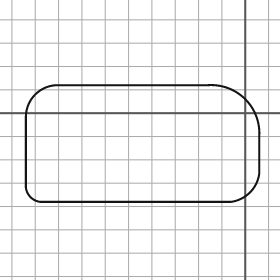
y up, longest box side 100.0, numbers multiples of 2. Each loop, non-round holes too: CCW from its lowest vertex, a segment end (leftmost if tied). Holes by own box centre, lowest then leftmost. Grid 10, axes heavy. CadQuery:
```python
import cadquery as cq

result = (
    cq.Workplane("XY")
    .moveTo(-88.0, -38.0)
    .lineTo(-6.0, -38.0)
    .threePointArc((2.0, -34.0), (6.0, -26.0))
    .lineTo(6.0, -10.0)
    .threePointArc((0.0, 6.0), (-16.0, 12.0))
    .lineTo(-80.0, 12.0)
    .threePointArc((-90.0, 8.0), (-94.0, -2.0))
    .lineTo(-94.0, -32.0)
    .threePointArc((-92.0, -36.0), (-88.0, -38.0))
    .close()
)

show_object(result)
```